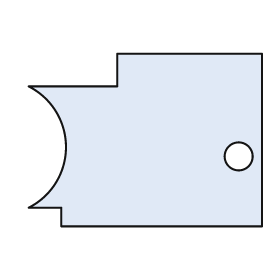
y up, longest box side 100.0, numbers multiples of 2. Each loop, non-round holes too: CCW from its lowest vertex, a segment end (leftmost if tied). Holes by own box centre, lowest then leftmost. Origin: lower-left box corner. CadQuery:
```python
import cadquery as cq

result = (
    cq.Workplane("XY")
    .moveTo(14.0, 0.0)
    .lineTo(100.0, 0.0)
    .lineTo(100.0, 74.0)
    .lineTo(38.0, 74.0)
    .lineTo(38.0, 60.0)
    .lineTo(0.0, 60.0)
    .threePointArc((16.0, 34.0), (0.0, 8.0))
    .lineTo(14.0, 8.0)
    .close()
    .moveTo(90.0, 30.0)
    .circle(6.0)
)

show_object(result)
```